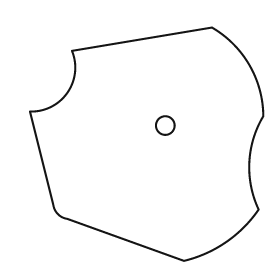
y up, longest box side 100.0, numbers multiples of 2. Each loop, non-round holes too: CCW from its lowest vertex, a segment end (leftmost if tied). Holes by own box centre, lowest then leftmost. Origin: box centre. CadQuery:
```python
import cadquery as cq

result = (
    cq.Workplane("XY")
    .moveTo(16.0, -50.0)
    .threePointArc((34.0, -42.0), (48.0, -28.0))
    .threePointArc((44.0, -8.0), (50.0, 12.0))
    .threePointArc((44.0, 34.0), (28.0, 50.0))
    .lineTo(-32.0, 40.0)
    .threePointArc((-34.0, 22.0), (-50.0, 14.0))
    .lineTo(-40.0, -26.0)
    .threePointArc((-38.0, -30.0), (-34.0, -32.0))
    .close()
    .moveTo(8.0, 8.0)
    .circle(4.0)
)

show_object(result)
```